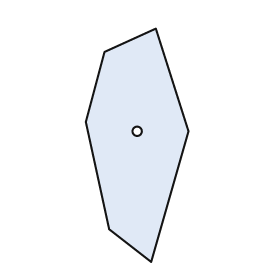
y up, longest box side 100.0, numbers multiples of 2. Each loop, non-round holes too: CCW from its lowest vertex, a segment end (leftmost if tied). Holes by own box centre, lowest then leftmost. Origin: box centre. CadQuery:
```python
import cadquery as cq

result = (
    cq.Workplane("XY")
    .moveTo(6.0, -50.0)
    .lineTo(22.0, 6.0)
    .lineTo(8.0, 50.0)
    .lineTo(-14.0, 40.0)
    .lineTo(-22.0, 10.0)
    .lineTo(-12.0, -36.0)
    .close()
    .moveTo(0.0, 6.0)
    .circle(2.0)
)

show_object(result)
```